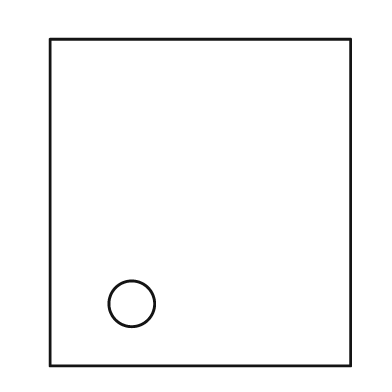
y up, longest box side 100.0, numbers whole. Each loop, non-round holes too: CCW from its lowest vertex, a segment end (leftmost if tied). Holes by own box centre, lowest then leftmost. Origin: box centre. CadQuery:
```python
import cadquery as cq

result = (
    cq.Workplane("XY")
    .moveTo(-46.0, -50.0)
    .lineTo(46.0, -50.0)
    .lineTo(46.0, 50.0)
    .lineTo(-46.0, 50.0)
    .close()
    .moveTo(-21.0, -31.0)
    .circle(7.0)
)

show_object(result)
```